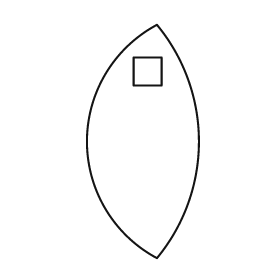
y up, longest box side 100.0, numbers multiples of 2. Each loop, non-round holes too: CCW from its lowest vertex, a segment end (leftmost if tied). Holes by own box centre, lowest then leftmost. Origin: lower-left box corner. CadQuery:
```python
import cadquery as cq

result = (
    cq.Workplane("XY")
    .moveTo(30.0, 0.0)
    .threePointArc((48.0, 50.0), (30.0, 100.0))
    .threePointArc((0.0, 50.0), (30.0, 0.0))
    .close()
    .moveTo(20.0, 74.0)
    .lineTo(32.0, 74.0)
    .lineTo(32.0, 86.0)
    .lineTo(20.0, 86.0)
    .close()
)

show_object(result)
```